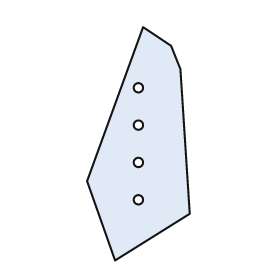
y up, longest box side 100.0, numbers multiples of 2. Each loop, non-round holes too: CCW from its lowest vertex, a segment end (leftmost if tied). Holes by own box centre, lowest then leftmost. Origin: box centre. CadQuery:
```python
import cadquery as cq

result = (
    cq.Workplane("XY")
    .moveTo(-10.0, -50.0)
    .lineTo(22.0, -30.0)
    .lineTo(18.0, 32.0)
    .lineTo(14.0, 42.0)
    .lineTo(2.0, 50.0)
    .lineTo(-22.0, -16.0)
    .close()
    .moveTo(0.0, -24.0)
    .circle(2.0)
    .moveTo(0.0, -8.0)
    .circle(2.0)
    .moveTo(0.0, 8.0)
    .circle(2.0)
    .moveTo(0.0, 24.0)
    .circle(2.0)
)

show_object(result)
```